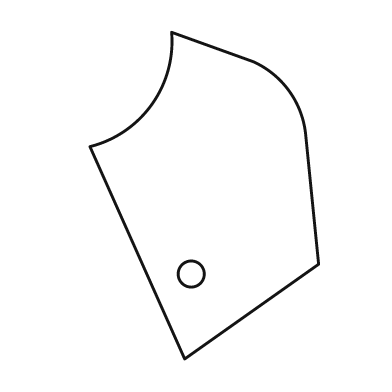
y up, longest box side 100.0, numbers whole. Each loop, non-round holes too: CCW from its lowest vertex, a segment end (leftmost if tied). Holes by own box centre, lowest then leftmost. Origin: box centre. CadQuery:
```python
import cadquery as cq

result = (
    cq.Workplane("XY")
    .moveTo(-6.0, -50.0)
    .lineTo(35.0, -21.0)
    .lineTo(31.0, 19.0)
    .threePointArc((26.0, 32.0), (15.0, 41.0))
    .lineTo(-10.0, 50.0)
    .threePointArc((-16.0, 28.0), (-35.0, 15.0))
    .close()
    .moveTo(-4.0, -24.0)
    .circle(4.0)
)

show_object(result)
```